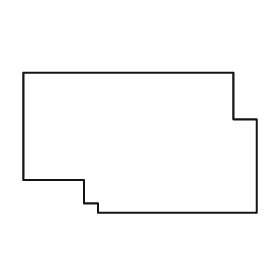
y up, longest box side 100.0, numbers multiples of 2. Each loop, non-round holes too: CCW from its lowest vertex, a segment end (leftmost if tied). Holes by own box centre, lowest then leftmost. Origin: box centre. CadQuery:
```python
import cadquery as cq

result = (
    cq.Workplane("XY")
    .moveTo(-18.0, -30.0)
    .lineTo(50.0, -30.0)
    .lineTo(50.0, 10.0)
    .lineTo(40.0, 10.0)
    .lineTo(40.0, 30.0)
    .lineTo(-50.0, 30.0)
    .lineTo(-50.0, -16.0)
    .lineTo(-24.0, -16.0)
    .lineTo(-24.0, -26.0)
    .lineTo(-18.0, -26.0)
    .close()
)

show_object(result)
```